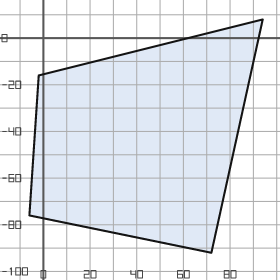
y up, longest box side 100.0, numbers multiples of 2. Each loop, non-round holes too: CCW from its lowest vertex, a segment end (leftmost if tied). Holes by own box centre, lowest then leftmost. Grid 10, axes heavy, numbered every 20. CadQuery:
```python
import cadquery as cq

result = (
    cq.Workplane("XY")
    .moveTo(72.0, -92.0)
    .lineTo(94.0, 8.0)
    .lineTo(-2.0, -16.0)
    .lineTo(-6.0, -76.0)
    .close()
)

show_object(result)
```